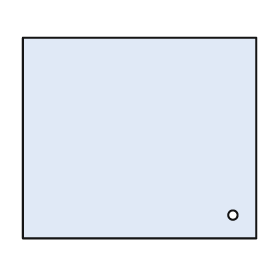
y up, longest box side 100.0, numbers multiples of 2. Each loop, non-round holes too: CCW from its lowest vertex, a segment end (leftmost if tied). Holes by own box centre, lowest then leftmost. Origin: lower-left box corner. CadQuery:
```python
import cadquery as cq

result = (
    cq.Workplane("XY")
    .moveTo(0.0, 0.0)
    .lineTo(100.0, 0.0)
    .lineTo(100.0, 86.0)
    .lineTo(0.0, 86.0)
    .close()
    .moveTo(90.0, 10.0)
    .circle(2.0)
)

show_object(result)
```